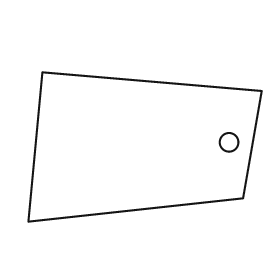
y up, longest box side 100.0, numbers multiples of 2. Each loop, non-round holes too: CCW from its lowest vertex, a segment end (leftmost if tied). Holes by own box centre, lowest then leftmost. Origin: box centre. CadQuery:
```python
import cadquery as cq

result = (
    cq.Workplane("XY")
    .moveTo(-50.0, -32.0)
    .lineTo(42.0, -22.0)
    .lineTo(50.0, 24.0)
    .lineTo(-44.0, 32.0)
    .close()
    .moveTo(36.0, 2.0)
    .circle(4.0)
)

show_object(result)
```